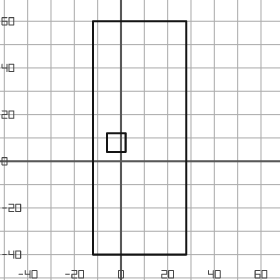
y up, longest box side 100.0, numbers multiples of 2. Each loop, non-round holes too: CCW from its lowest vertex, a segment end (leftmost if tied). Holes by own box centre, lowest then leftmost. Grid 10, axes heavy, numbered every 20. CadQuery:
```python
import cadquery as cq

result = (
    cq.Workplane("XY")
    .moveTo(-12.0, -40.0)
    .lineTo(28.0, -40.0)
    .lineTo(28.0, 60.0)
    .lineTo(-12.0, 60.0)
    .close()
    .moveTo(-6.0, 4.0)
    .lineTo(2.0, 4.0)
    .lineTo(2.0, 12.0)
    .lineTo(-6.0, 12.0)
    .close()
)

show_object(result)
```